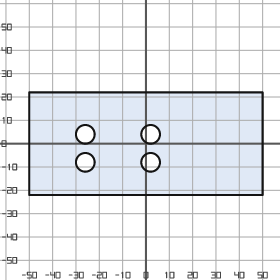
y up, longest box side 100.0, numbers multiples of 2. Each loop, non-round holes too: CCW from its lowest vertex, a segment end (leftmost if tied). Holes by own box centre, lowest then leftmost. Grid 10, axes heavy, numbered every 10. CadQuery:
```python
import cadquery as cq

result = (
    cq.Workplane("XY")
    .moveTo(-50.0, -22.0)
    .lineTo(50.0, -22.0)
    .lineTo(50.0, 22.0)
    .lineTo(-50.0, 22.0)
    .close()
    .moveTo(-26.0, -8.0)
    .circle(4.0)
    .moveTo(2.0, -8.0)
    .circle(4.0)
    .moveTo(-26.0, 4.0)
    .circle(4.0)
    .moveTo(2.0, 4.0)
    .circle(4.0)
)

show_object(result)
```